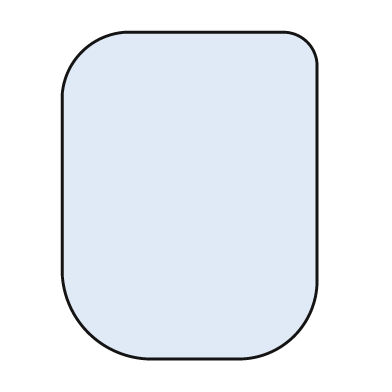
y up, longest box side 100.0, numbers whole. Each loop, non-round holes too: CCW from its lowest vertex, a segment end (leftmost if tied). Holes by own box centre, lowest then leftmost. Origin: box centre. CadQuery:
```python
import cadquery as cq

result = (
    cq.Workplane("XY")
    .moveTo(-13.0, -50.0)
    .lineTo(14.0, -50.0)
    .threePointArc((32.0, -43.0), (39.0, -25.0))
    .lineTo(39.0, 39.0)
    .threePointArc((36.0, 47.0), (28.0, 50.0))
    .lineTo(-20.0, 50.0)
    .threePointArc((-33.0, 44.0), (-39.0, 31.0))
    .lineTo(-39.0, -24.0)
    .threePointArc((-31.0, -42.0), (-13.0, -50.0))
    .close()
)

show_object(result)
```